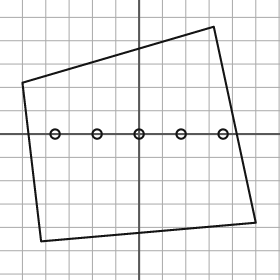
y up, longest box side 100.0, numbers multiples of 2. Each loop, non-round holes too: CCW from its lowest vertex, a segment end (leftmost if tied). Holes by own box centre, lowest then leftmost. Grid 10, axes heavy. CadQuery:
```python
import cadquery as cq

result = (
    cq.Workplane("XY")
    .moveTo(-42.0, -46.0)
    .lineTo(50.0, -38.0)
    .lineTo(32.0, 46.0)
    .lineTo(-50.0, 22.0)
    .close()
    .moveTo(-36.0, 0.0)
    .circle(2.0)
    .moveTo(-18.0, 0.0)
    .circle(2.0)
    .moveTo(0.0, 0.0)
    .circle(2.0)
    .moveTo(18.0, 0.0)
    .circle(2.0)
    .moveTo(36.0, 0.0)
    .circle(2.0)
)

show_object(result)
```